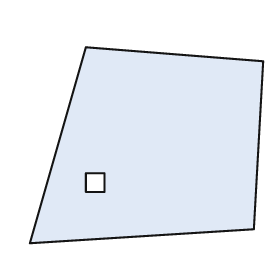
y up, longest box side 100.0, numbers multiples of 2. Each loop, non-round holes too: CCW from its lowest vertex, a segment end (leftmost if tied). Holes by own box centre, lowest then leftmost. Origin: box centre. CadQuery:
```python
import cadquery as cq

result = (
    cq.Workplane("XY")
    .moveTo(-50.0, -42.0)
    .lineTo(46.0, -36.0)
    .lineTo(50.0, 36.0)
    .lineTo(-26.0, 42.0)
    .close()
    .moveTo(-26.0, -20.0)
    .lineTo(-18.0, -20.0)
    .lineTo(-18.0, -12.0)
    .lineTo(-26.0, -12.0)
    .close()
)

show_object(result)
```